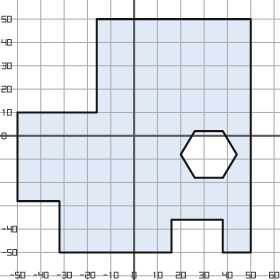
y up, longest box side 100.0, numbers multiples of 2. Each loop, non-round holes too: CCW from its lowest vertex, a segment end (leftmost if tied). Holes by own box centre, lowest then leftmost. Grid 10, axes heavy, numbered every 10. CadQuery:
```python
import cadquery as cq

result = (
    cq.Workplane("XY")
    .moveTo(-32.0, -50.0)
    .lineTo(16.0, -50.0)
    .lineTo(16.0, -36.0)
    .lineTo(38.0, -36.0)
    .lineTo(38.0, -50.0)
    .lineTo(50.0, -50.0)
    .lineTo(50.0, 50.0)
    .lineTo(-16.0, 50.0)
    .lineTo(-16.0, 10.0)
    .lineTo(-50.0, 10.0)
    .lineTo(-50.0, -28.0)
    .lineTo(-32.0, -28.0)
    .close()
    .moveTo(26.0, -18.0)
    .lineTo(38.0, -18.0)
    .lineTo(44.0, -8.0)
    .lineTo(38.0, 2.0)
    .lineTo(26.0, 2.0)
    .lineTo(20.0, -8.0)
    .close()
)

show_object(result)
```